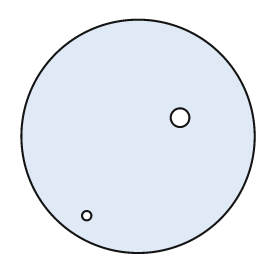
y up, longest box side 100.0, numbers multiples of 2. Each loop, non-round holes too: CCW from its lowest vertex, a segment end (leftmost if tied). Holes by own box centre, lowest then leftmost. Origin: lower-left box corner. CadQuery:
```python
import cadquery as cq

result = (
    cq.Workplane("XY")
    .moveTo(50.0, 50.0)
    .circle(50.0)
    .moveTo(28.0, 16.0)
    .circle(2.0)
    .moveTo(68.0, 58.0)
    .circle(4.0)
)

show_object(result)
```